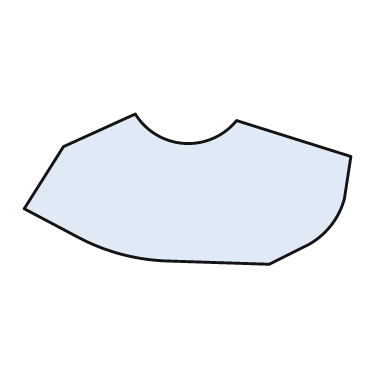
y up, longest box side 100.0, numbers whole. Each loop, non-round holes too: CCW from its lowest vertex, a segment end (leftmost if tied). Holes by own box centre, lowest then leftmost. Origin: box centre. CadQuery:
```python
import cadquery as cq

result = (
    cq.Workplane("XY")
    .moveTo(25.0, -23.0)
    .lineTo(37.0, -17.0)
    .threePointArc((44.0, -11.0), (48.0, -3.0))
    .lineTo(50.0, 10.0)
    .lineTo(15.0, 21.0)
    .threePointArc((-1.0, 14.0), (-16.0, 23.0))
    .lineTo(-38.0, 13.0)
    .lineTo(-50.0, -6.0)
    .lineTo(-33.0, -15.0)
    .threePointArc((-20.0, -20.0), (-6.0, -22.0))
    .close()
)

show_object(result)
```